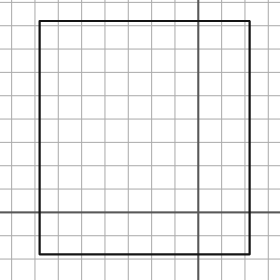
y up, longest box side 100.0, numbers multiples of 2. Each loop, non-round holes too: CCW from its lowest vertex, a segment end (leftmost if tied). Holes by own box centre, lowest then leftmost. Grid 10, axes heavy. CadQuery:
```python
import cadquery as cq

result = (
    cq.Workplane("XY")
    .moveTo(-68.0, -18.0)
    .lineTo(22.0, -18.0)
    .lineTo(22.0, 82.0)
    .lineTo(-68.0, 82.0)
    .close()
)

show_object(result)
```